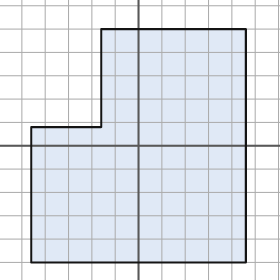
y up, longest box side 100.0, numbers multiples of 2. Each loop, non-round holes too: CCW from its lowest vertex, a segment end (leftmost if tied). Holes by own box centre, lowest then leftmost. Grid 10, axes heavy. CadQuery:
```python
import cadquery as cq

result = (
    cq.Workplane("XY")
    .moveTo(-46.0, -50.0)
    .lineTo(46.0, -50.0)
    .lineTo(46.0, 50.0)
    .lineTo(-16.0, 50.0)
    .lineTo(-16.0, 8.0)
    .lineTo(-46.0, 8.0)
    .close()
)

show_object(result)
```